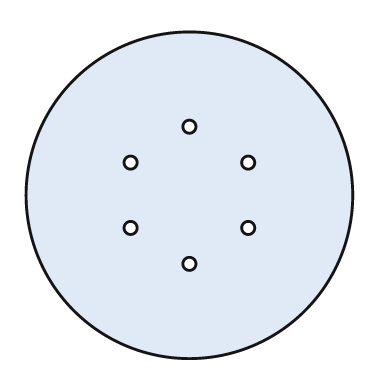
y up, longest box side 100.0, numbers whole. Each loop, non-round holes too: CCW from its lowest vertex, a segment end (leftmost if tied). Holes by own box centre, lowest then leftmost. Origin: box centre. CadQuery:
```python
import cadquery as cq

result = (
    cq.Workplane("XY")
    .moveTo(0.0, 0.0)
    .circle(50.0)
    .moveTo(0.0, -21.0)
    .circle(2.0)
    .moveTo(-18.0, -10.0)
    .circle(2.0)
    .moveTo(18.0, -10.0)
    .circle(2.0)
    .moveTo(-18.0, 10.0)
    .circle(2.0)
    .moveTo(18.0, 10.0)
    .circle(2.0)
    .moveTo(0.0, 21.0)
    .circle(2.0)
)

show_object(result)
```